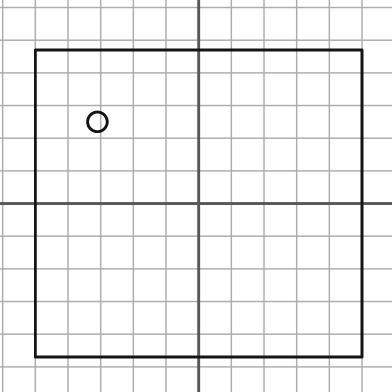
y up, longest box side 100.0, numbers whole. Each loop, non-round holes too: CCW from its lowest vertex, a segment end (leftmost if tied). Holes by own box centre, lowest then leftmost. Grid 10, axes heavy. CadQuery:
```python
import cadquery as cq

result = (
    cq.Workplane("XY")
    .moveTo(-50.0, -47.0)
    .lineTo(50.0, -47.0)
    .lineTo(50.0, 47.0)
    .lineTo(-50.0, 47.0)
    .close()
    .moveTo(-31.0, 25.0)
    .circle(3.0)
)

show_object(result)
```